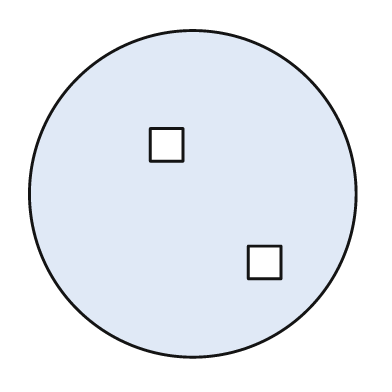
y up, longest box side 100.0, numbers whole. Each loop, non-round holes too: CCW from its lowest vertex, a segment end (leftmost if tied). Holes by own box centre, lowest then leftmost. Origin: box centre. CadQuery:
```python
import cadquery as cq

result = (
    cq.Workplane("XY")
    .moveTo(0.0, 0.0)
    .circle(50.0)
    .moveTo(17.0, -26.0)
    .lineTo(27.0, -26.0)
    .lineTo(27.0, -16.0)
    .lineTo(17.0, -16.0)
    .close()
    .moveTo(-13.0, 10.0)
    .lineTo(-3.0, 10.0)
    .lineTo(-3.0, 20.0)
    .lineTo(-13.0, 20.0)
    .close()
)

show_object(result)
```